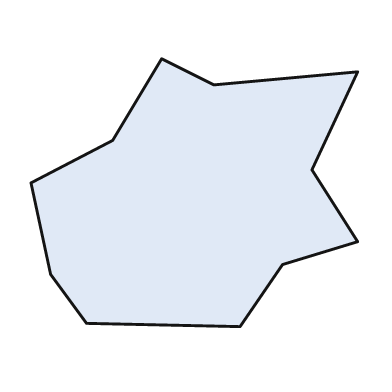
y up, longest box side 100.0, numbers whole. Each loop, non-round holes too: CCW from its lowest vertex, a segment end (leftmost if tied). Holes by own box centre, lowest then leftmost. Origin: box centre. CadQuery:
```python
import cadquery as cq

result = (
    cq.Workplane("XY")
    .moveTo(14.0, -41.0)
    .lineTo(27.0, -22.0)
    .lineTo(50.0, -15.0)
    .lineTo(36.0, 7.0)
    .lineTo(50.0, 37.0)
    .lineTo(6.0, 33.0)
    .lineTo(-10.0, 41.0)
    .lineTo(-25.0, 16.0)
    .lineTo(-50.0, 3.0)
    .lineTo(-44.0, -25.0)
    .lineTo(-33.0, -40.0)
    .close()
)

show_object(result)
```